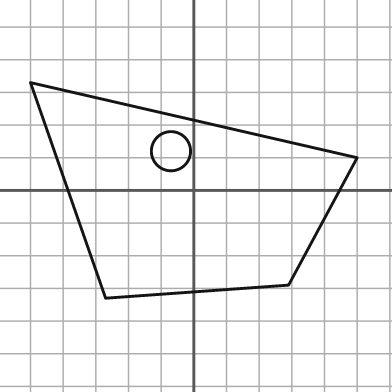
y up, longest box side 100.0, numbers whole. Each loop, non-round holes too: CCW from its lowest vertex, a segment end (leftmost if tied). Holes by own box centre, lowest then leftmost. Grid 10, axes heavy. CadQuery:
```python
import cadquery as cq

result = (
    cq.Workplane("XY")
    .moveTo(-27.0, -33.0)
    .lineTo(29.0, -29.0)
    .lineTo(50.0, 10.0)
    .lineTo(-50.0, 33.0)
    .close()
    .moveTo(-7.0, 12.0)
    .circle(6.0)
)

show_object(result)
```